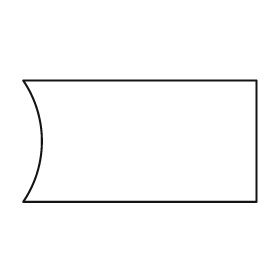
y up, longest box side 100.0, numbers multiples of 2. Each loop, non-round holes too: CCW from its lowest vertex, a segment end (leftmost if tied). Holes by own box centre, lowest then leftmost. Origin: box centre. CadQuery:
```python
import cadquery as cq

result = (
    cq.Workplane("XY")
    .moveTo(-50.0, -26.0)
    .lineTo(50.0, -26.0)
    .lineTo(50.0, 26.0)
    .lineTo(-50.0, 26.0)
    .threePointArc((-42.0, 0.0), (-50.0, -26.0))
    .close()
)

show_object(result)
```